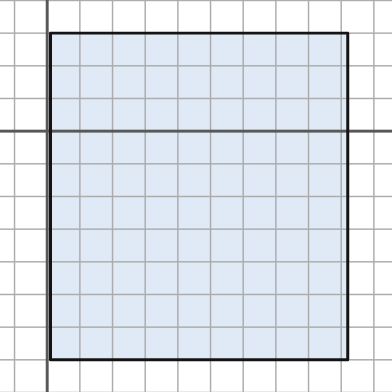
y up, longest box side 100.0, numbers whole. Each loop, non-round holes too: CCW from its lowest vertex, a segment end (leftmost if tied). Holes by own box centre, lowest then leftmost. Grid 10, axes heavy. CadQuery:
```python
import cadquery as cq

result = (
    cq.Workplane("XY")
    .moveTo(1.0, -70.0)
    .lineTo(92.0, -70.0)
    .lineTo(92.0, 30.0)
    .lineTo(1.0, 30.0)
    .close()
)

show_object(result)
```